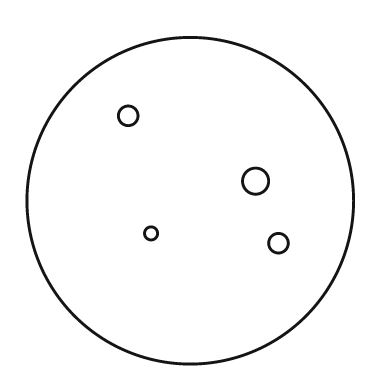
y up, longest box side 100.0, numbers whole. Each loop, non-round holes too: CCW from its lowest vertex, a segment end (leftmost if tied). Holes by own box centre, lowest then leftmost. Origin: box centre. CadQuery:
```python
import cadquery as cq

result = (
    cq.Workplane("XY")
    .moveTo(0.0, 0.0)
    .circle(50.0)
    .moveTo(27.0, -13.0)
    .circle(3.0)
    .moveTo(-12.0, -10.0)
    .circle(2.0)
    .moveTo(20.0, 6.0)
    .circle(4.0)
    .moveTo(-19.0, 26.0)
    .circle(3.0)
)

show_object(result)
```